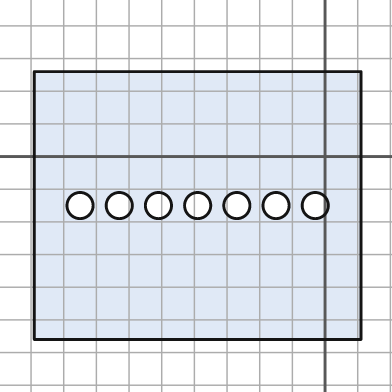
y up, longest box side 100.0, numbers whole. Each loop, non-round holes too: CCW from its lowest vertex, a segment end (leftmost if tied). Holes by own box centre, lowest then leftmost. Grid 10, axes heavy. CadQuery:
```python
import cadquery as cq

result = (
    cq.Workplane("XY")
    .moveTo(-89.0, -56.0)
    .lineTo(11.0, -56.0)
    .lineTo(11.0, 26.0)
    .lineTo(-89.0, 26.0)
    .close()
    .moveTo(-75.0, -15.0)
    .circle(4.0)
    .moveTo(-63.0, -15.0)
    .circle(4.0)
    .moveTo(-51.0, -15.0)
    .circle(4.0)
    .moveTo(-39.0, -15.0)
    .circle(4.0)
    .moveTo(-27.0, -15.0)
    .circle(4.0)
    .moveTo(-15.0, -15.0)
    .circle(4.0)
    .moveTo(-3.0, -15.0)
    .circle(4.0)
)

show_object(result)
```